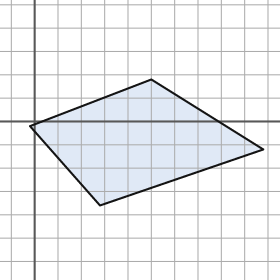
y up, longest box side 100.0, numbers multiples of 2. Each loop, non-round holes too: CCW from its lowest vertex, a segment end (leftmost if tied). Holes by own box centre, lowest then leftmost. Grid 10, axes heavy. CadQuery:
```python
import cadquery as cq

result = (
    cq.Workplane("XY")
    .moveTo(28.0, -36.0)
    .lineTo(98.0, -12.0)
    .lineTo(50.0, 18.0)
    .lineTo(-2.0, -2.0)
    .close()
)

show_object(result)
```